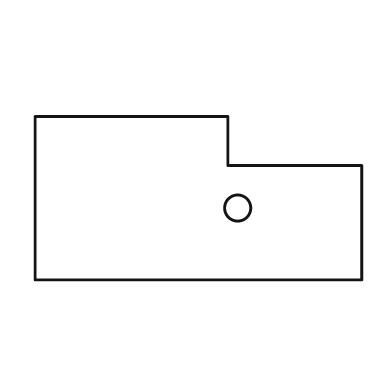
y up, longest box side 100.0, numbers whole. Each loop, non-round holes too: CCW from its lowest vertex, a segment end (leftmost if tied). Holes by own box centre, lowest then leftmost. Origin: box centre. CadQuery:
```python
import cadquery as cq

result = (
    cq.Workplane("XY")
    .moveTo(-50.0, -25.0)
    .lineTo(50.0, -25.0)
    .lineTo(50.0, 10.0)
    .lineTo(9.0, 10.0)
    .lineTo(9.0, 25.0)
    .lineTo(-50.0, 25.0)
    .close()
    .moveTo(12.0, -3.0)
    .circle(4.0)
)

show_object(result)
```